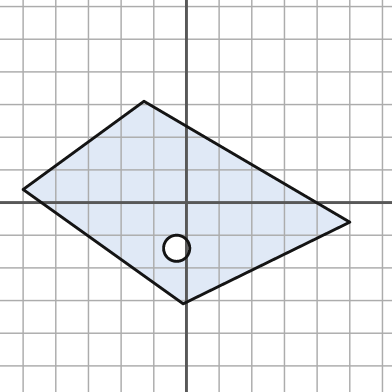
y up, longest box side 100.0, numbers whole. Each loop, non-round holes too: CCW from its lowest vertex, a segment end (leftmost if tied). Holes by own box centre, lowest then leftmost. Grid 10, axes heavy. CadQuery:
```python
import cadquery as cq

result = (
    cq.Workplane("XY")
    .moveTo(-1.0, -31.0)
    .lineTo(50.0, -6.0)
    .lineTo(-13.0, 31.0)
    .lineTo(-50.0, 4.0)
    .close()
    .moveTo(-3.0, -14.0)
    .circle(4.0)
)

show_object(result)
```